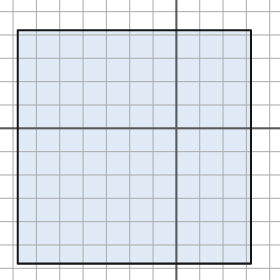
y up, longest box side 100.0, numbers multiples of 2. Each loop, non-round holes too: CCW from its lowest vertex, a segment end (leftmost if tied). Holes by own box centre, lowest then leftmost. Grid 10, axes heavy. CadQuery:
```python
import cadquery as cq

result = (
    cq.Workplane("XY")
    .moveTo(-68.0, -58.0)
    .lineTo(32.0, -58.0)
    .lineTo(32.0, 42.0)
    .lineTo(-68.0, 42.0)
    .close()
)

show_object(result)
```